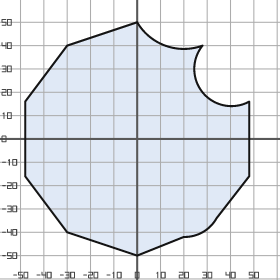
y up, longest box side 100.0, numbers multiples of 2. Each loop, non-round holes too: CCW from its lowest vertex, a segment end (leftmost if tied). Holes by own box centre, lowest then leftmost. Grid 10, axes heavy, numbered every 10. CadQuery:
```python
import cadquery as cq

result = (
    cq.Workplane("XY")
    .moveTo(0.0, -50.0)
    .lineTo(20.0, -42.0)
    .threePointArc((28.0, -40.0), (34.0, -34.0))
    .lineTo(48.0, -16.0)
    .lineTo(48.0, 16.0)
    .threePointArc((28.0, 20.0), (28.0, 40.0))
    .threePointArc((12.0, 40.0), (0.0, 50.0))
    .lineTo(-30.0, 40.0)
    .lineTo(-48.0, 16.0)
    .lineTo(-48.0, -16.0)
    .lineTo(-30.0, -40.0)
    .close()
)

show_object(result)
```